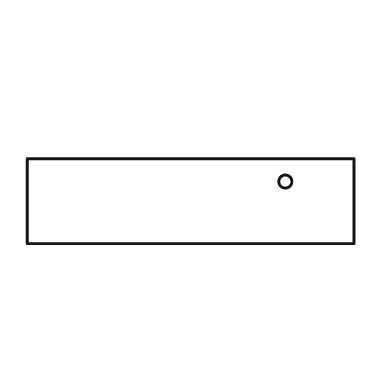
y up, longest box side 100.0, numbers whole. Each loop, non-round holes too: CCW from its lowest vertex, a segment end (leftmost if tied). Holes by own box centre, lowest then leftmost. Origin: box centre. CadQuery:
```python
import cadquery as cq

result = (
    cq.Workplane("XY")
    .moveTo(-50.0, -13.0)
    .lineTo(50.0, -13.0)
    .lineTo(50.0, 13.0)
    .lineTo(-50.0, 13.0)
    .close()
    .moveTo(29.0, 6.0)
    .circle(2.0)
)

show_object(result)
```